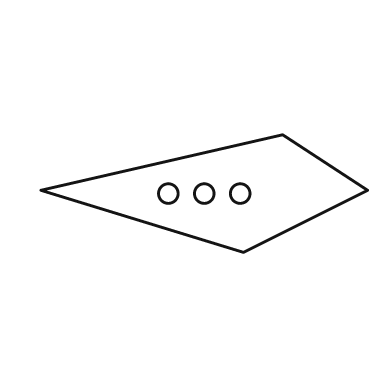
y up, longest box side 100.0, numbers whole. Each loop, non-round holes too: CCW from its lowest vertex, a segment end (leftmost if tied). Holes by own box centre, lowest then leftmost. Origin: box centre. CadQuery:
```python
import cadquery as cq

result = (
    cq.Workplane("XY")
    .moveTo(12.0, -18.0)
    .lineTo(50.0, 1.0)
    .lineTo(24.0, 18.0)
    .lineTo(-50.0, 1.0)
    .close()
    .moveTo(-11.0, 0.0)
    .circle(3.0)
    .moveTo(0.0, 0.0)
    .circle(3.0)
    .moveTo(11.0, 0.0)
    .circle(3.0)
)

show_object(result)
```